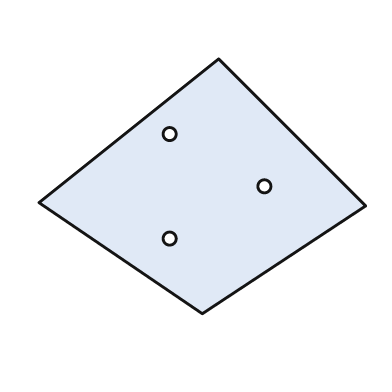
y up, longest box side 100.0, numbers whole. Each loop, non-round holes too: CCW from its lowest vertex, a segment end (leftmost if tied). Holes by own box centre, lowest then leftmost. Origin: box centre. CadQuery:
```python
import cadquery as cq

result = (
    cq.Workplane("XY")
    .moveTo(0.0, -39.0)
    .lineTo(50.0, -6.0)
    .lineTo(5.0, 39.0)
    .lineTo(-50.0, -5.0)
    .close()
    .moveTo(-10.0, -16.0)
    .circle(2.0)
    .moveTo(19.0, 0.0)
    .circle(2.0)
    .moveTo(-10.0, 16.0)
    .circle(2.0)
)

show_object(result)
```